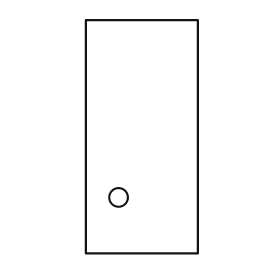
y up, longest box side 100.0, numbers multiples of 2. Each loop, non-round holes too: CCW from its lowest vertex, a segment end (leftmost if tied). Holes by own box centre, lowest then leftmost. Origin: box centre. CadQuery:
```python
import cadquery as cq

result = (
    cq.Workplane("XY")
    .moveTo(-24.0, -50.0)
    .lineTo(24.0, -50.0)
    .lineTo(24.0, 50.0)
    .lineTo(-24.0, 50.0)
    .close()
    .moveTo(-10.0, -26.0)
    .circle(4.0)
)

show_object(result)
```